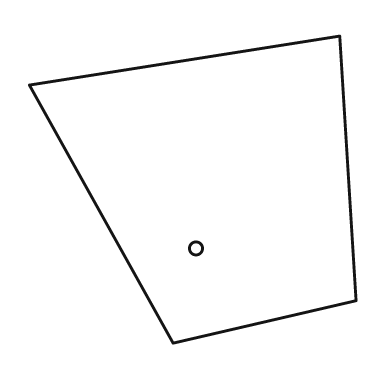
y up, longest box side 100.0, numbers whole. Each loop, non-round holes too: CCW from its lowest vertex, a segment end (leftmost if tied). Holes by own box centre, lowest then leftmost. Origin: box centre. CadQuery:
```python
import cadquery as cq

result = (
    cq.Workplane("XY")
    .moveTo(-6.0, -47.0)
    .lineTo(50.0, -34.0)
    .lineTo(45.0, 47.0)
    .lineTo(-50.0, 32.0)
    .close()
    .moveTo(1.0, -18.0)
    .circle(2.0)
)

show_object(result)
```